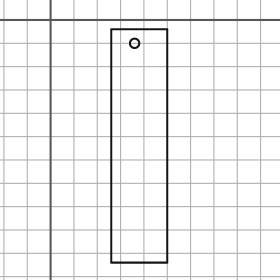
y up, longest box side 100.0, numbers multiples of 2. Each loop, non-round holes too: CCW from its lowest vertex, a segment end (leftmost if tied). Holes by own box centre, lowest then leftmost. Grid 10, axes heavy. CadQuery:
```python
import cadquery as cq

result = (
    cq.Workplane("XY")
    .moveTo(26.0, -104.0)
    .lineTo(50.0, -104.0)
    .lineTo(50.0, -4.0)
    .lineTo(26.0, -4.0)
    .close()
    .moveTo(36.0, -10.0)
    .circle(2.0)
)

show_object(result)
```